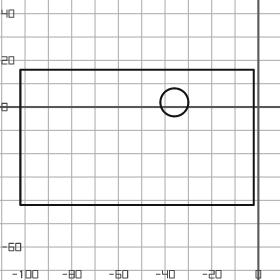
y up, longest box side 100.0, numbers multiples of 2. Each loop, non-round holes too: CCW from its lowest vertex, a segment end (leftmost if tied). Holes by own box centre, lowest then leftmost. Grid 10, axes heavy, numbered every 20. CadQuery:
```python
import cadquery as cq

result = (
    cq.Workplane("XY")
    .moveTo(-102.0, -42.0)
    .lineTo(-2.0, -42.0)
    .lineTo(-2.0, 16.0)
    .lineTo(-102.0, 16.0)
    .close()
    .moveTo(-36.0, 2.0)
    .circle(6.0)
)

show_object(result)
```